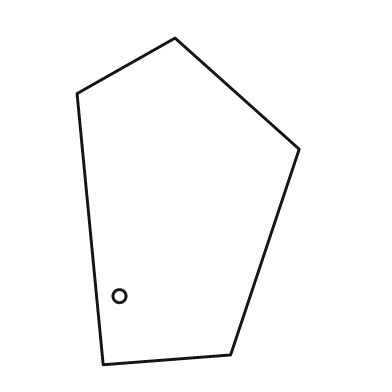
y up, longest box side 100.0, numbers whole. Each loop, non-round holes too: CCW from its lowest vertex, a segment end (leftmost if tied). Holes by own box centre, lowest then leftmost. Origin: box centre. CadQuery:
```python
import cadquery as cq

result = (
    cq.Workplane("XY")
    .moveTo(-26.0, -50.0)
    .lineTo(13.0, -47.0)
    .lineTo(34.0, 16.0)
    .lineTo(-4.0, 50.0)
    .lineTo(-34.0, 33.0)
    .close()
    .moveTo(-21.0, -29.0)
    .circle(2.0)
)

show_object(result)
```